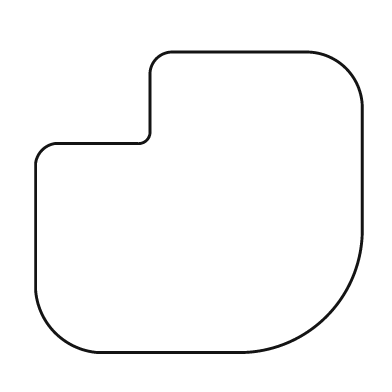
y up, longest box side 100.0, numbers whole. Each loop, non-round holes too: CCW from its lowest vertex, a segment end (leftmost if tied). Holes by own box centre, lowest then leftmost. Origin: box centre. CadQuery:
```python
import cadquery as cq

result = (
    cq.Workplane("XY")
    .moveTo(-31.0, -46.0)
    .lineTo(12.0, -46.0)
    .threePointArc((39.0, -35.0), (50.0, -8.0))
    .lineTo(50.0, 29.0)
    .threePointArc((45.0, 41.0), (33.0, 46.0))
    .lineTo(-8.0, 46.0)
    .threePointArc((-13.0, 44.0), (-15.0, 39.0))
    .lineTo(-15.0, 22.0)
    .threePointArc((-16.0, 19.0), (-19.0, 18.0))
    .lineTo(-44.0, 18.0)
    .threePointArc((-48.0, 16.0), (-50.0, 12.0))
    .lineTo(-50.0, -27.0)
    .threePointArc((-44.0, -40.0), (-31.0, -46.0))
    .close()
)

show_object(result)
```